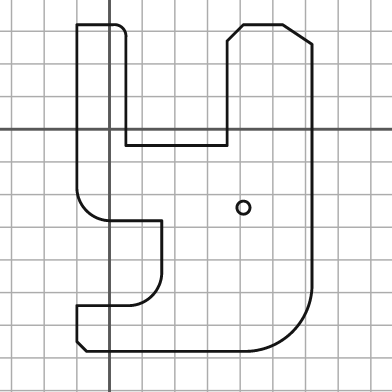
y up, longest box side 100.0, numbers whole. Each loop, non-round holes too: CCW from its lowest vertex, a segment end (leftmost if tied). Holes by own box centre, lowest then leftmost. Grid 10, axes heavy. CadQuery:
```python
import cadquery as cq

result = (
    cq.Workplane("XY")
    .moveTo(-7.0, -68.0)
    .lineTo(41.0, -68.0)
    .threePointArc((56.0, -62.0), (62.0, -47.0))
    .lineTo(62.0, 26.0)
    .lineTo(53.0, 32.0)
    .lineTo(41.0, 32.0)
    .lineTo(36.0, 27.0)
    .lineTo(36.0, -5.0)
    .lineTo(5.0, -5.0)
    .lineTo(5.0, 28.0)
    .threePointArc((4.0, 31.0), (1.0, 32.0))
    .lineTo(-10.0, 32.0)
    .lineTo(-10.0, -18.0)
    .threePointArc((-7.0, -25.0), (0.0, -28.0))
    .lineTo(16.0, -28.0)
    .lineTo(16.0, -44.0)
    .threePointArc((13.0, -51.0), (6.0, -54.0))
    .lineTo(-10.0, -54.0)
    .lineTo(-10.0, -65.0)
    .close()
    .moveTo(41.0, -24.0)
    .circle(2.0)
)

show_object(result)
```